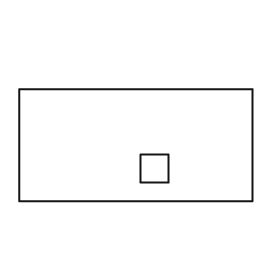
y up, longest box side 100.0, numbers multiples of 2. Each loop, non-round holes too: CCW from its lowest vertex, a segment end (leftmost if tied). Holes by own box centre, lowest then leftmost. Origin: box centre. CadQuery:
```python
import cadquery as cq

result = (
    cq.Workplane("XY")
    .moveTo(-50.0, -24.0)
    .lineTo(50.0, -24.0)
    .lineTo(50.0, 24.0)
    .lineTo(-50.0, 24.0)
    .close()
    .moveTo(2.0, -16.0)
    .lineTo(14.0, -16.0)
    .lineTo(14.0, -4.0)
    .lineTo(2.0, -4.0)
    .close()
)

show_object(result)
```